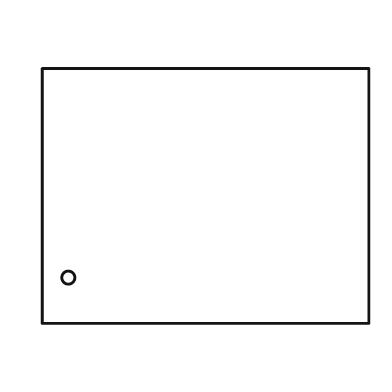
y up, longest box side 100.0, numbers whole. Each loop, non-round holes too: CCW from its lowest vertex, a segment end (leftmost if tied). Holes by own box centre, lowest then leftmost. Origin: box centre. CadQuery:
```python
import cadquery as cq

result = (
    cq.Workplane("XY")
    .moveTo(-50.0, -39.0)
    .lineTo(50.0, -39.0)
    .lineTo(50.0, 39.0)
    .lineTo(-50.0, 39.0)
    .close()
    .moveTo(-42.0, -25.0)
    .circle(2.0)
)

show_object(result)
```